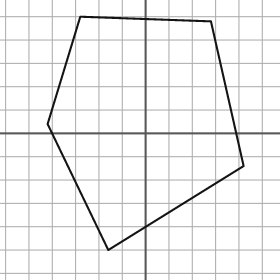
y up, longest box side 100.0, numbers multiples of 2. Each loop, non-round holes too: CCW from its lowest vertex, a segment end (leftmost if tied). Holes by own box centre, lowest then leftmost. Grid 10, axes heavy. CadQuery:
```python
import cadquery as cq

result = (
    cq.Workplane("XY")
    .moveTo(-16.0, -50.0)
    .lineTo(42.0, -14.0)
    .lineTo(28.0, 48.0)
    .lineTo(-28.0, 50.0)
    .lineTo(-42.0, 4.0)
    .close()
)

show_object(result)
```